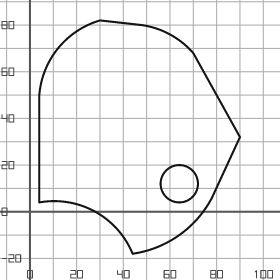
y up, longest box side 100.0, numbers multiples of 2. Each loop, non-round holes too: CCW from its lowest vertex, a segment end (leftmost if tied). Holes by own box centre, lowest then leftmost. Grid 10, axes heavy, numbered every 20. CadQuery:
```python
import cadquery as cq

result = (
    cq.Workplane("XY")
    .moveTo(44.0, -18.0)
    .threePointArc((64.0, -10.0), (78.0, 6.0))
    .lineTo(90.0, 32.0)
    .lineTo(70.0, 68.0)
    .threePointArc((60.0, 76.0), (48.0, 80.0))
    .lineTo(30.0, 82.0)
    .threePointArc((12.0, 70.0), (4.0, 50.0))
    .lineTo(4.0, 4.0)
    .threePointArc((28.0, 0.0), (44.0, -18.0))
    .close()
    .moveTo(64.0, 12.0)
    .circle(8.0)
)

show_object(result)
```